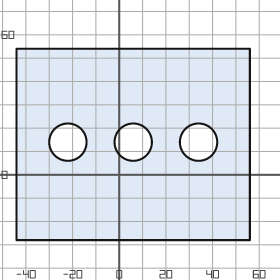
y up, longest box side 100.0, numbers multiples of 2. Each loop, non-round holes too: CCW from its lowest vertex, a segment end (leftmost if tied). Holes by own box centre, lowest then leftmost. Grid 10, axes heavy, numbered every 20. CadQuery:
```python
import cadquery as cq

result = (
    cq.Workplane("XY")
    .moveTo(-44.0, -28.0)
    .lineTo(56.0, -28.0)
    .lineTo(56.0, 54.0)
    .lineTo(-44.0, 54.0)
    .close()
    .moveTo(-22.0, 14.0)
    .circle(8.0)
    .moveTo(6.0, 14.0)
    .circle(8.0)
    .moveTo(34.0, 14.0)
    .circle(8.0)
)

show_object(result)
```